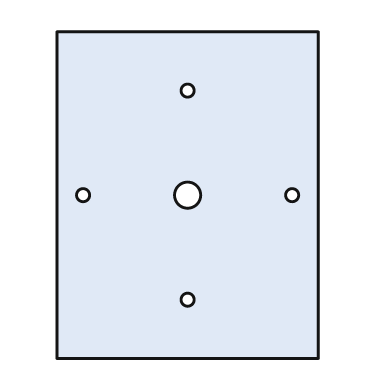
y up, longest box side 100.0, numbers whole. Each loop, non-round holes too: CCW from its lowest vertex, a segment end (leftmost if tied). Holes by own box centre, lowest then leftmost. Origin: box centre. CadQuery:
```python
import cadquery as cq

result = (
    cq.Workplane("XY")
    .moveTo(-40.0, -50.0)
    .lineTo(40.0, -50.0)
    .lineTo(40.0, 50.0)
    .lineTo(-40.0, 50.0)
    .close()
    .moveTo(0.0, -32.0)
    .circle(2.0)
    .moveTo(-32.0, 0.0)
    .circle(2.0)
    .moveTo(0.0, 0.0)
    .circle(4.0)
    .moveTo(32.0, 0.0)
    .circle(2.0)
    .moveTo(0.0, 32.0)
    .circle(2.0)
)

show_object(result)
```